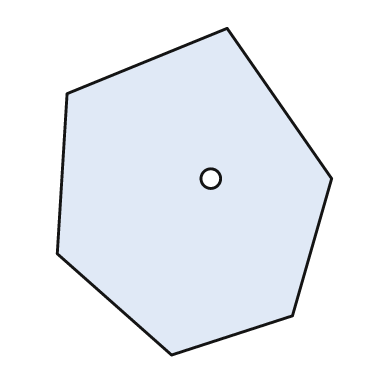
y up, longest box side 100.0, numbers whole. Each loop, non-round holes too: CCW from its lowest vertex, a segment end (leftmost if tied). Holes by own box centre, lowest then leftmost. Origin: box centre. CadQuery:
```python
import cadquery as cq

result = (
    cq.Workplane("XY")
    .moveTo(-7.0, -50.0)
    .lineTo(30.0, -38.0)
    .lineTo(42.0, 4.0)
    .lineTo(10.0, 50.0)
    .lineTo(-39.0, 30.0)
    .lineTo(-42.0, -19.0)
    .close()
    .moveTo(5.0, 4.0)
    .circle(3.0)
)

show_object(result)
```